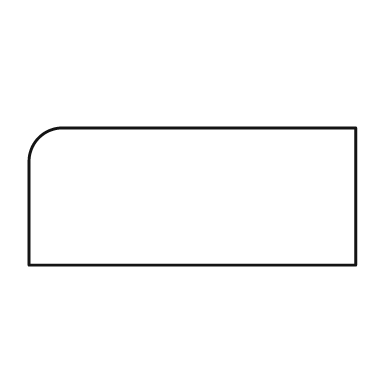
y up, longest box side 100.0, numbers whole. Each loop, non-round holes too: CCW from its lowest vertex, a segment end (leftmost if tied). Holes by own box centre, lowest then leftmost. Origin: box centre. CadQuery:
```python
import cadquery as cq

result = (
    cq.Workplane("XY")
    .moveTo(-50.0, -21.0)
    .lineTo(50.0, -21.0)
    .lineTo(50.0, 21.0)
    .lineTo(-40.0, 21.0)
    .threePointArc((-47.0, 18.0), (-50.0, 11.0))
    .close()
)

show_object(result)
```